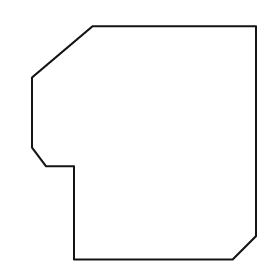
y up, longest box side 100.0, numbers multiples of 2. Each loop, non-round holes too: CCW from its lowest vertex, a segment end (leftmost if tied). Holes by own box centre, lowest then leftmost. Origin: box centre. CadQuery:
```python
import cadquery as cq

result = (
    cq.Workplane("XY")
    .moveTo(-30.0, -50.0)
    .lineTo(38.0, -50.0)
    .lineTo(48.0, -40.0)
    .lineTo(48.0, 50.0)
    .lineTo(-22.0, 50.0)
    .lineTo(-48.0, 28.0)
    .lineTo(-48.0, -2.0)
    .lineTo(-42.0, -10.0)
    .lineTo(-30.0, -10.0)
    .close()
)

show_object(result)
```